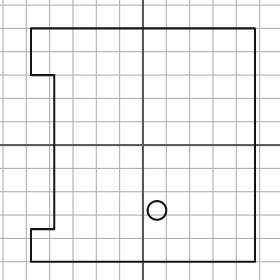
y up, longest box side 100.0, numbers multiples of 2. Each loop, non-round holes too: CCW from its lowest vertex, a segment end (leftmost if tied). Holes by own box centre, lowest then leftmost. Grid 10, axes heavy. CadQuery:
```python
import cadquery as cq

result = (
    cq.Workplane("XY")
    .moveTo(-48.0, -50.0)
    .lineTo(48.0, -50.0)
    .lineTo(48.0, 50.0)
    .lineTo(-48.0, 50.0)
    .lineTo(-48.0, 30.0)
    .lineTo(-38.0, 30.0)
    .lineTo(-38.0, -36.0)
    .lineTo(-48.0, -36.0)
    .close()
    .moveTo(6.0, -28.0)
    .circle(4.0)
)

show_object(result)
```